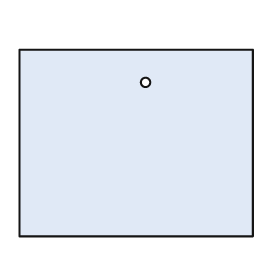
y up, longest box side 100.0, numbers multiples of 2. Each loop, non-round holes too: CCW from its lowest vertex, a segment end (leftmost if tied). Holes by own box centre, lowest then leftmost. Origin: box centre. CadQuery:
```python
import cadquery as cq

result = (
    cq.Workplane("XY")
    .moveTo(-50.0, -40.0)
    .lineTo(50.0, -40.0)
    .lineTo(50.0, 40.0)
    .lineTo(-50.0, 40.0)
    .close()
    .moveTo(4.0, 26.0)
    .circle(2.0)
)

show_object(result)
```